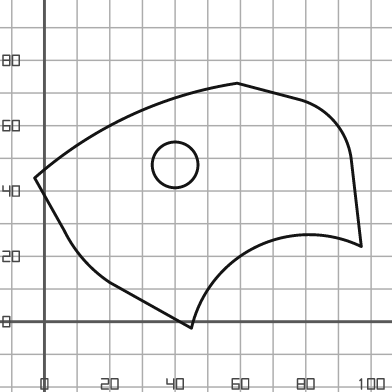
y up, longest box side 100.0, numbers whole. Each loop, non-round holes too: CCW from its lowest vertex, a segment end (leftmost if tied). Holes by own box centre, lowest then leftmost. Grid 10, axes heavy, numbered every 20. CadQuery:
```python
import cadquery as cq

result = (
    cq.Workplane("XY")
    .moveTo(45.0, -2.0)
    .threePointArc((65.0, 23.0), (97.0, 23.0))
    .lineTo(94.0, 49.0)
    .threePointArc((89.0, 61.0), (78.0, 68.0))
    .lineTo(59.0, 73.0)
    .threePointArc((26.0, 63.0), (-3.0, 44.0))
    .lineTo(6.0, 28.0)
    .threePointArc((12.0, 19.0), (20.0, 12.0))
    .close()
    .moveTo(40.0, 48.0)
    .circle(7.0)
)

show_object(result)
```